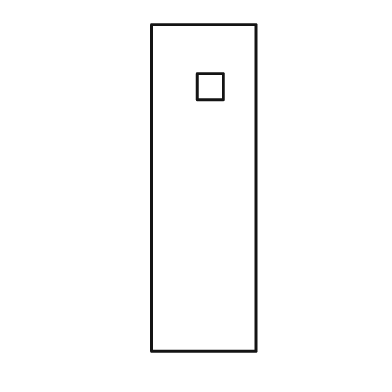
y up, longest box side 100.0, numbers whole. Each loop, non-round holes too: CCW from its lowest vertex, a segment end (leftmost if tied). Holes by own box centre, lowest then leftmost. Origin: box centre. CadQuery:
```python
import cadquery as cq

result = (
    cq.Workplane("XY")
    .moveTo(-16.0, -50.0)
    .lineTo(16.0, -50.0)
    .lineTo(16.0, 50.0)
    .lineTo(-16.0, 50.0)
    .close()
    .moveTo(-2.0, 27.0)
    .lineTo(6.0, 27.0)
    .lineTo(6.0, 35.0)
    .lineTo(-2.0, 35.0)
    .close()
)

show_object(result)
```